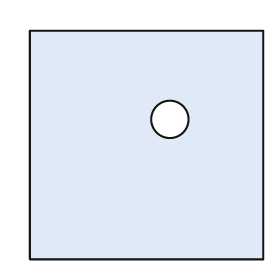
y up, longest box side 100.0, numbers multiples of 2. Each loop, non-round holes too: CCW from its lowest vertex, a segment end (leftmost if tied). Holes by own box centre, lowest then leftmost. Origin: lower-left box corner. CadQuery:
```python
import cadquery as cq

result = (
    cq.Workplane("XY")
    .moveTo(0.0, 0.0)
    .lineTo(100.0, 0.0)
    .lineTo(100.0, 98.0)
    .lineTo(0.0, 98.0)
    .close()
    .moveTo(60.0, 60.0)
    .circle(8.0)
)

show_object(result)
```